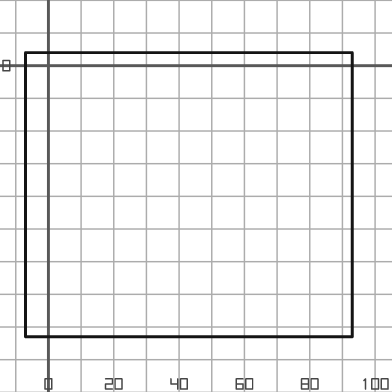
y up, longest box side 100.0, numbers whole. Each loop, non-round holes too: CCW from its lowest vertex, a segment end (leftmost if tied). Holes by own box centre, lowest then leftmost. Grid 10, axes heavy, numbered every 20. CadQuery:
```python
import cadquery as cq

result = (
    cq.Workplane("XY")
    .moveTo(-7.0, -83.0)
    .lineTo(93.0, -83.0)
    .lineTo(93.0, 4.0)
    .lineTo(-7.0, 4.0)
    .close()
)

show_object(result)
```